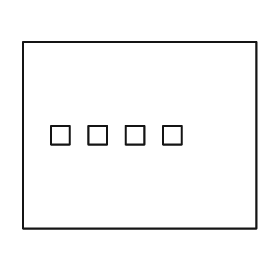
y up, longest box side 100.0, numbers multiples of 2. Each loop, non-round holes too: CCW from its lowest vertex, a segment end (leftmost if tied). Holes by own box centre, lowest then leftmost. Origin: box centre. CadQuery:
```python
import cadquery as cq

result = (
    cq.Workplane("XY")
    .moveTo(-50.0, -40.0)
    .lineTo(50.0, -40.0)
    .lineTo(50.0, 40.0)
    .lineTo(-50.0, 40.0)
    .close()
    .moveTo(-38.0, -4.0)
    .lineTo(-30.0, -4.0)
    .lineTo(-30.0, 4.0)
    .lineTo(-38.0, 4.0)
    .close()
    .moveTo(-22.0, -4.0)
    .lineTo(-14.0, -4.0)
    .lineTo(-14.0, 4.0)
    .lineTo(-22.0, 4.0)
    .close()
    .moveTo(-6.0, -4.0)
    .lineTo(2.0, -4.0)
    .lineTo(2.0, 4.0)
    .lineTo(-6.0, 4.0)
    .close()
    .moveTo(10.0, -4.0)
    .lineTo(18.0, -4.0)
    .lineTo(18.0, 4.0)
    .lineTo(10.0, 4.0)
    .close()
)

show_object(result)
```